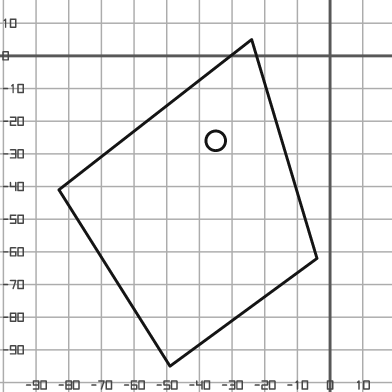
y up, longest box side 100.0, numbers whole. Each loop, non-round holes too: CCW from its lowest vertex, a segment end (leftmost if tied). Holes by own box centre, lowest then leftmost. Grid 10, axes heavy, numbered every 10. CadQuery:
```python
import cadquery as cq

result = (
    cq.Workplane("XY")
    .moveTo(-49.0, -95.0)
    .lineTo(-4.0, -62.0)
    .lineTo(-24.0, 5.0)
    .lineTo(-83.0, -41.0)
    .close()
    .moveTo(-35.0, -26.0)
    .circle(3.0)
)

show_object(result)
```